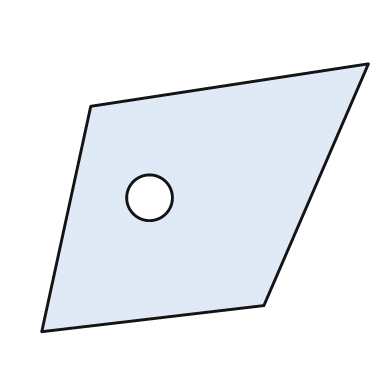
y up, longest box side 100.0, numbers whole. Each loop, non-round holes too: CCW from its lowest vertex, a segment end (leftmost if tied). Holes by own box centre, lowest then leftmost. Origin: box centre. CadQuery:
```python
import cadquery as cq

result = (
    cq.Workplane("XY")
    .moveTo(-50.0, -41.0)
    .lineTo(18.0, -33.0)
    .lineTo(50.0, 41.0)
    .lineTo(-35.0, 28.0)
    .close()
    .moveTo(-17.0, 0.0)
    .circle(7.0)
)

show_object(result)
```